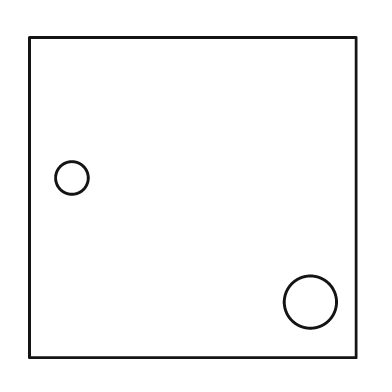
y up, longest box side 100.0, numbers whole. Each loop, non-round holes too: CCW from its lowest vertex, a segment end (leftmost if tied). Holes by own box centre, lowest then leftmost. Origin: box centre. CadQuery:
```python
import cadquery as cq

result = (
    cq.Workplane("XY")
    .moveTo(-50.0, -49.0)
    .lineTo(50.0, -49.0)
    .lineTo(50.0, 49.0)
    .lineTo(-50.0, 49.0)
    .close()
    .moveTo(36.0, -32.0)
    .circle(8.0)
    .moveTo(-37.0, 6.0)
    .circle(5.0)
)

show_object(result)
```